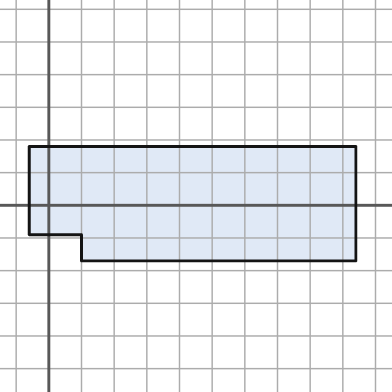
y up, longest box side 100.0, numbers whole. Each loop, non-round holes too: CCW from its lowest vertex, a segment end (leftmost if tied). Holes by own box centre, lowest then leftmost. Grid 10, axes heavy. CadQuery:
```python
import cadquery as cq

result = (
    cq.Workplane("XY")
    .moveTo(10.0, -17.0)
    .lineTo(94.0, -17.0)
    .lineTo(94.0, 18.0)
    .lineTo(-6.0, 18.0)
    .lineTo(-6.0, -9.0)
    .lineTo(10.0, -9.0)
    .close()
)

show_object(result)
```